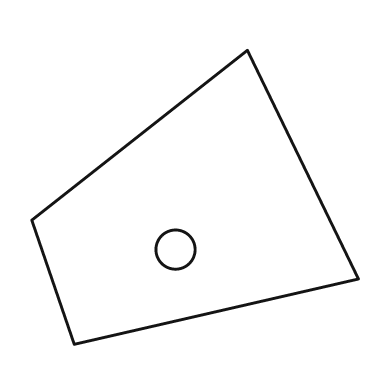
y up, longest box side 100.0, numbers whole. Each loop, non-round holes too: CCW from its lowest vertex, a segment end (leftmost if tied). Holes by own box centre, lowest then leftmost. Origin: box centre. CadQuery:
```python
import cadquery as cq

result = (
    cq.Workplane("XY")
    .moveTo(-37.0, -45.0)
    .lineTo(50.0, -25.0)
    .lineTo(16.0, 45.0)
    .lineTo(-50.0, -7.0)
    .close()
    .moveTo(-6.0, -16.0)
    .circle(6.0)
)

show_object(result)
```